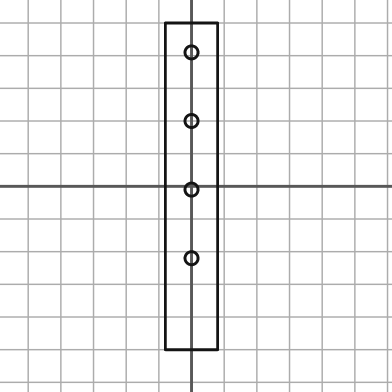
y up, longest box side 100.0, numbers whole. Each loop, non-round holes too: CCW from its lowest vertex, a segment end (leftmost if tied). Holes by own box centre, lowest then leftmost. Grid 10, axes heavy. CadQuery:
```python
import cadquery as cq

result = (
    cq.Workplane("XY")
    .moveTo(-8.0, -50.0)
    .lineTo(8.0, -50.0)
    .lineTo(8.0, 50.0)
    .lineTo(-8.0, 50.0)
    .close()
    .moveTo(0.0, -22.0)
    .circle(2.0)
    .moveTo(0.0, -1.0)
    .circle(2.0)
    .moveTo(0.0, 20.0)
    .circle(2.0)
    .moveTo(0.0, 41.0)
    .circle(2.0)
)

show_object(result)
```